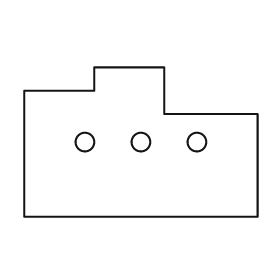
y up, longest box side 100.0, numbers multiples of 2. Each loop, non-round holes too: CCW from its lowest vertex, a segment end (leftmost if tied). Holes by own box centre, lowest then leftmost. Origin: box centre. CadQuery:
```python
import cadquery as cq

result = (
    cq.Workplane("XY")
    .moveTo(-50.0, -32.0)
    .lineTo(50.0, -32.0)
    .lineTo(50.0, 12.0)
    .lineTo(10.0, 12.0)
    .lineTo(10.0, 32.0)
    .lineTo(-20.0, 32.0)
    .lineTo(-20.0, 22.0)
    .lineTo(-50.0, 22.0)
    .close()
    .moveTo(-24.0, 0.0)
    .circle(4.0)
    .moveTo(0.0, 0.0)
    .circle(4.0)
    .moveTo(24.0, 0.0)
    .circle(4.0)
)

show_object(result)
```